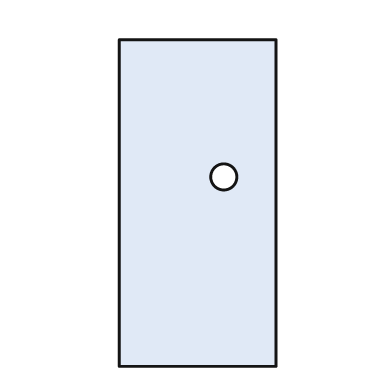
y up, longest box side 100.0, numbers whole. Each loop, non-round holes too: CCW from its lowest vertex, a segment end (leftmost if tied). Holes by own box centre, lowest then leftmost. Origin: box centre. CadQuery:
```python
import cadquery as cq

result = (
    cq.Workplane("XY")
    .moveTo(-24.0, -50.0)
    .lineTo(24.0, -50.0)
    .lineTo(24.0, 50.0)
    .lineTo(-24.0, 50.0)
    .close()
    .moveTo(8.0, 8.0)
    .circle(4.0)
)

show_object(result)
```